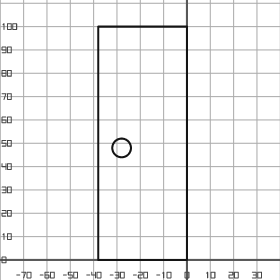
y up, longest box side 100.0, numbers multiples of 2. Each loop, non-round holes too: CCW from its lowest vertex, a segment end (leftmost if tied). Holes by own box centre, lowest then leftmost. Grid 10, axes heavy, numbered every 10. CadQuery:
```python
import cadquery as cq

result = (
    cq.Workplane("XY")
    .moveTo(-38.0, 0.0)
    .lineTo(0.0, 0.0)
    .lineTo(0.0, 100.0)
    .lineTo(-38.0, 100.0)
    .close()
    .moveTo(-28.0, 48.0)
    .circle(4.0)
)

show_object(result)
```